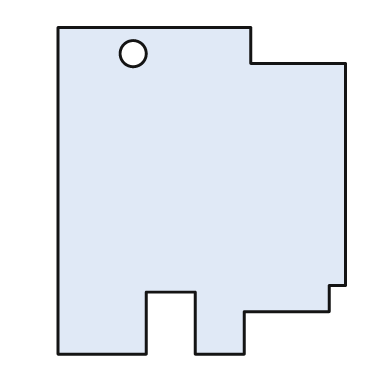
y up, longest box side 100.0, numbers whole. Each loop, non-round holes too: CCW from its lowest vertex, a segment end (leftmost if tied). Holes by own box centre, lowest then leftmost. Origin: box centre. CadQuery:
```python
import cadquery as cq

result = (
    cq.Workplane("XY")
    .moveTo(-44.0, -50.0)
    .lineTo(-17.0, -50.0)
    .lineTo(-17.0, -31.0)
    .lineTo(-2.0, -31.0)
    .lineTo(-2.0, -50.0)
    .lineTo(13.0, -50.0)
    .lineTo(13.0, -37.0)
    .lineTo(39.0, -37.0)
    .lineTo(39.0, -29.0)
    .lineTo(44.0, -29.0)
    .lineTo(44.0, 39.0)
    .lineTo(15.0, 39.0)
    .lineTo(15.0, 50.0)
    .lineTo(-44.0, 50.0)
    .close()
    .moveTo(-21.0, 42.0)
    .circle(4.0)
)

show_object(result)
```